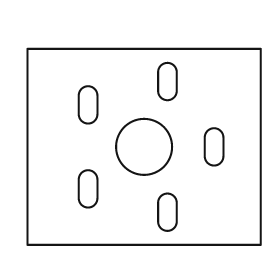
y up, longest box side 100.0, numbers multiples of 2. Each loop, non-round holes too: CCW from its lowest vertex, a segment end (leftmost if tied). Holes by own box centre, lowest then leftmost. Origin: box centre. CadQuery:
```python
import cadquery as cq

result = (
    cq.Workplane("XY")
    .moveTo(-50.0, -42.0)
    .lineTo(50.0, -42.0)
    .lineTo(50.0, 42.0)
    .lineTo(-50.0, 42.0)
    .close()
    .moveTo(6.0, -32.0)
    .threePointArc((10.0, -36.0), (14.0, -32.0))
    .lineTo(14.0, -24.0)
    .threePointArc((10.0, -20.0), (6.0, -24.0))
    .close()
    .moveTo(-28.0, -22.0)
    .threePointArc((-24.0, -26.0), (-20.0, -22.0))
    .lineTo(-20.0, -14.0)
    .threePointArc((-24.0, -10.0), (-28.0, -14.0))
    .close()
    .moveTo(0.0, 0.0)
    .circle(12.0)
    .moveTo(26.0, -4.0)
    .threePointArc((30.0, -8.0), (34.0, -4.0))
    .lineTo(34.0, 4.0)
    .threePointArc((30.0, 8.0), (26.0, 4.0))
    .close()
    .moveTo(-28.0, 14.0)
    .threePointArc((-24.0, 10.0), (-20.0, 14.0))
    .lineTo(-20.0, 22.0)
    .threePointArc((-24.0, 26.0), (-28.0, 22.0))
    .close()
    .moveTo(6.0, 24.0)
    .threePointArc((10.0, 20.0), (14.0, 24.0))
    .lineTo(14.0, 32.0)
    .threePointArc((10.0, 36.0), (6.0, 32.0))
    .close()
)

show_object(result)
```